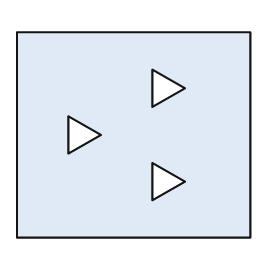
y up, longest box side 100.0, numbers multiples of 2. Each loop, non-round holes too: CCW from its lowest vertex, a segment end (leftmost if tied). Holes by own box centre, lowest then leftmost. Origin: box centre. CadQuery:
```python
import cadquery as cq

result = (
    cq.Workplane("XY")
    .moveTo(-50.0, -44.0)
    .lineTo(50.0, -44.0)
    .lineTo(50.0, 44.0)
    .lineTo(-50.0, 44.0)
    .close()
    .moveTo(8.0, -28.0)
    .lineTo(22.0, -20.0)
    .lineTo(8.0, -12.0)
    .close()
    .moveTo(-28.0, -8.0)
    .lineTo(-14.0, 0.0)
    .lineTo(-28.0, 8.0)
    .close()
    .moveTo(8.0, 12.0)
    .lineTo(22.0, 20.0)
    .lineTo(8.0, 28.0)
    .close()
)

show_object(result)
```